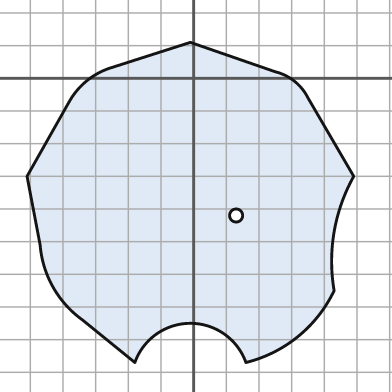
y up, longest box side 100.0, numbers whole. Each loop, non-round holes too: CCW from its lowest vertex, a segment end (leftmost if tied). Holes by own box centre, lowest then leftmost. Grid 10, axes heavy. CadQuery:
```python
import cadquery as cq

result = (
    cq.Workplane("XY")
    .moveTo(-18.0, -87.0)
    .threePointArc((-1.0, -75.0), (16.0, -87.0))
    .threePointArc((32.0, -79.0), (43.0, -65.0))
    .threePointArc((43.0, -47.0), (49.0, -30.0))
    .lineTo(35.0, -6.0)
    .threePointArc((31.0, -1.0), (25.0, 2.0))
    .lineTo(-1.0, 11.0)
    .lineTo(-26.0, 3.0)
    .threePointArc((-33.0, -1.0), (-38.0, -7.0))
    .lineTo(-51.0, -30.0)
    .lineTo(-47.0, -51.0)
    .threePointArc((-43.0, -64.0), (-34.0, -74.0))
    .close()
    .moveTo(13.0, -42.0)
    .circle(2.0)
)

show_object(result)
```